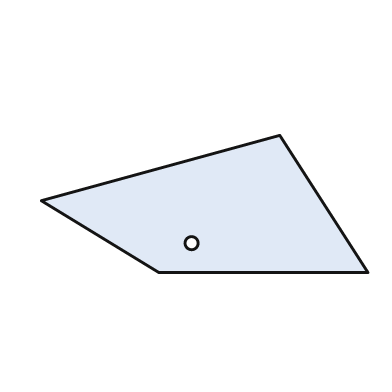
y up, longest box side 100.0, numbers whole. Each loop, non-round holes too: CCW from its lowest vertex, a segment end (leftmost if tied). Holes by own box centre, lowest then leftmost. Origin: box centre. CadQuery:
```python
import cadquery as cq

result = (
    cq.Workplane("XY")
    .moveTo(-14.0, -21.0)
    .lineTo(50.0, -21.0)
    .lineTo(23.0, 21.0)
    .lineTo(-50.0, 1.0)
    .close()
    .moveTo(-4.0, -12.0)
    .circle(2.0)
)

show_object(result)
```